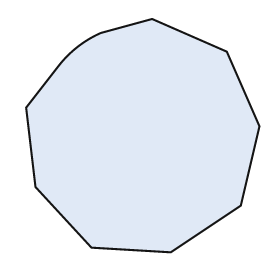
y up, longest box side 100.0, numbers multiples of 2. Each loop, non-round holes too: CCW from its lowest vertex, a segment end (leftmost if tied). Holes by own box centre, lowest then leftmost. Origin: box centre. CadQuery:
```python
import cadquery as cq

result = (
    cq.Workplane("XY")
    .moveTo(12.0, -50.0)
    .lineTo(42.0, -30.0)
    .lineTo(50.0, 4.0)
    .lineTo(36.0, 36.0)
    .lineTo(4.0, 50.0)
    .lineTo(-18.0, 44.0)
    .threePointArc((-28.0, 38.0), (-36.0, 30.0))
    .lineTo(-50.0, 12.0)
    .lineTo(-46.0, -22.0)
    .lineTo(-22.0, -48.0)
    .close()
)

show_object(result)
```